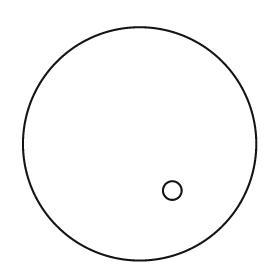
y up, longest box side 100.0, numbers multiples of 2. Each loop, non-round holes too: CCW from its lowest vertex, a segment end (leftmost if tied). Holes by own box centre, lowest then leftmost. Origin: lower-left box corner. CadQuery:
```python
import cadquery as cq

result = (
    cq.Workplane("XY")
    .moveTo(50.0, 50.0)
    .circle(50.0)
    .moveTo(64.0, 30.0)
    .circle(4.0)
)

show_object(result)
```